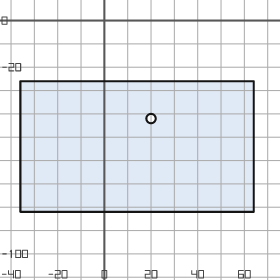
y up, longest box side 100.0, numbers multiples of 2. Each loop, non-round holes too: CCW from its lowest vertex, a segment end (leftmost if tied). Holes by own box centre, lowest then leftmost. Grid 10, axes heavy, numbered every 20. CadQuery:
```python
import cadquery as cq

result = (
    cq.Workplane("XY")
    .moveTo(-36.0, -82.0)
    .lineTo(64.0, -82.0)
    .lineTo(64.0, -26.0)
    .lineTo(-36.0, -26.0)
    .close()
    .moveTo(20.0, -42.0)
    .circle(2.0)
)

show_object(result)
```